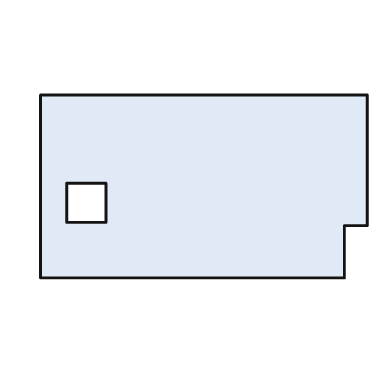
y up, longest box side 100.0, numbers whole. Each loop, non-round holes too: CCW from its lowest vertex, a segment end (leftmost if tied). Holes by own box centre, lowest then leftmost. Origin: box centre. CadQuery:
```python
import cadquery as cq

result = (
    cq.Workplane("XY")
    .moveTo(-50.0, -28.0)
    .lineTo(43.0, -28.0)
    .lineTo(43.0, -12.0)
    .lineTo(50.0, -12.0)
    .lineTo(50.0, 28.0)
    .lineTo(-50.0, 28.0)
    .close()
    .moveTo(-42.0, -11.0)
    .lineTo(-30.0, -11.0)
    .lineTo(-30.0, 1.0)
    .lineTo(-42.0, 1.0)
    .close()
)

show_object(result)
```